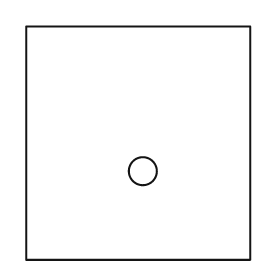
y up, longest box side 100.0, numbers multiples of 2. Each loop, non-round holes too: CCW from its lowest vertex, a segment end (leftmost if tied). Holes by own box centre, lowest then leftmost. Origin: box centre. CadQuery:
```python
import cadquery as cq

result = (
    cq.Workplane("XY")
    .moveTo(-48.0, -50.0)
    .lineTo(48.0, -50.0)
    .lineTo(48.0, 50.0)
    .lineTo(-48.0, 50.0)
    .close()
    .moveTo(2.0, -12.0)
    .circle(6.0)
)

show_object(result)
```